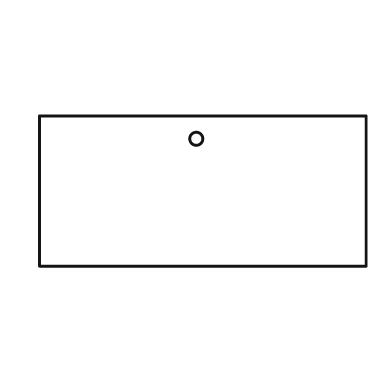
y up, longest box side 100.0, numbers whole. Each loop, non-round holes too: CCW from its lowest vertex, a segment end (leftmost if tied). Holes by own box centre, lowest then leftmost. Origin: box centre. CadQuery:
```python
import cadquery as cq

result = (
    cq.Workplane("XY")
    .moveTo(-50.0, -23.0)
    .lineTo(50.0, -23.0)
    .lineTo(50.0, 23.0)
    .lineTo(-50.0, 23.0)
    .close()
    .moveTo(-2.0, 16.0)
    .circle(2.0)
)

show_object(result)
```